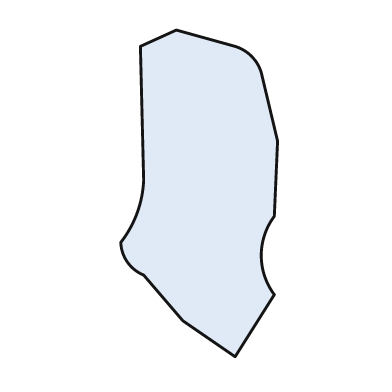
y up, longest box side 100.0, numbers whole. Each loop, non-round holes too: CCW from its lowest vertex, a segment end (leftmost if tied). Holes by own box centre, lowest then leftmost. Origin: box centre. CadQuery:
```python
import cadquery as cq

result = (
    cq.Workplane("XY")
    .moveTo(11.0, -50.0)
    .lineTo(23.0, -31.0)
    .threePointArc((19.0, -19.0), (23.0, -7.0))
    .lineTo(24.0, 16.0)
    .lineTo(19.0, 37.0)
    .threePointArc((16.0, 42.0), (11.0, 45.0))
    .lineTo(-7.0, 50.0)
    .lineTo(-18.0, 45.0)
    .lineTo(-17.0, 4.0)
    .threePointArc((-19.0, -6.0), (-24.0, -15.0))
    .threePointArc((-22.0, -21.0), (-17.0, -25.0))
    .lineTo(-5.0, -39.0)
    .close()
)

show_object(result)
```